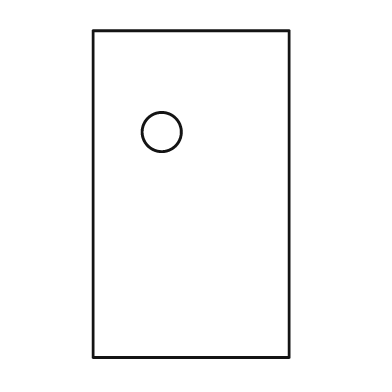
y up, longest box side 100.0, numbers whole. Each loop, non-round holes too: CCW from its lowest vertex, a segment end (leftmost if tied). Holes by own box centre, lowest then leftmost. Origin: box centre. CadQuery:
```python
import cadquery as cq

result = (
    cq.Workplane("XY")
    .moveTo(-30.0, -50.0)
    .lineTo(30.0, -50.0)
    .lineTo(30.0, 50.0)
    .lineTo(-30.0, 50.0)
    .close()
    .moveTo(-9.0, 19.0)
    .circle(6.0)
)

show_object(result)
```